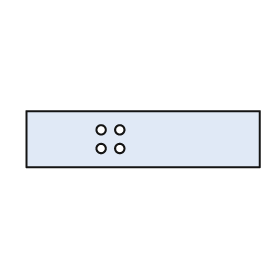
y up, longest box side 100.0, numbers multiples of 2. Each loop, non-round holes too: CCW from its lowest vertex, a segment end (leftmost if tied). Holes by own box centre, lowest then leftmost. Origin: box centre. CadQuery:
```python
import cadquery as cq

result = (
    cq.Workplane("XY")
    .moveTo(-50.0, -12.0)
    .lineTo(50.0, -12.0)
    .lineTo(50.0, 12.0)
    .lineTo(-50.0, 12.0)
    .close()
    .moveTo(-18.0, -4.0)
    .circle(2.0)
    .moveTo(-10.0, -4.0)
    .circle(2.0)
    .moveTo(-18.0, 4.0)
    .circle(2.0)
    .moveTo(-10.0, 4.0)
    .circle(2.0)
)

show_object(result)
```